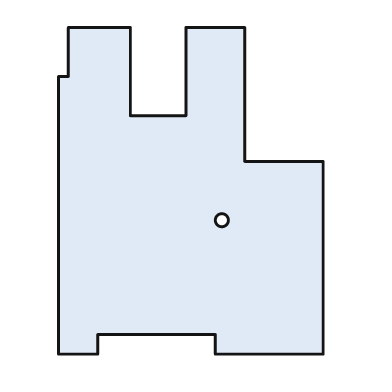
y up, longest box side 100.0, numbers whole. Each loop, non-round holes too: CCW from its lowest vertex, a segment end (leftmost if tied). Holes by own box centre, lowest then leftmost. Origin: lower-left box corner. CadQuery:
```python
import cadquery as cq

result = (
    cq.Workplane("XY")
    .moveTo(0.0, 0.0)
    .lineTo(12.0, 0.0)
    .lineTo(12.0, 6.0)
    .lineTo(48.0, 6.0)
    .lineTo(48.0, 0.0)
    .lineTo(81.0, 0.0)
    .lineTo(81.0, 59.0)
    .lineTo(57.0, 59.0)
    .lineTo(57.0, 100.0)
    .lineTo(39.0, 100.0)
    .lineTo(39.0, 73.0)
    .lineTo(22.0, 73.0)
    .lineTo(22.0, 100.0)
    .lineTo(3.0, 100.0)
    .lineTo(3.0, 85.0)
    .lineTo(0.0, 85.0)
    .close()
    .moveTo(50.0, 41.0)
    .circle(2.0)
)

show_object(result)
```